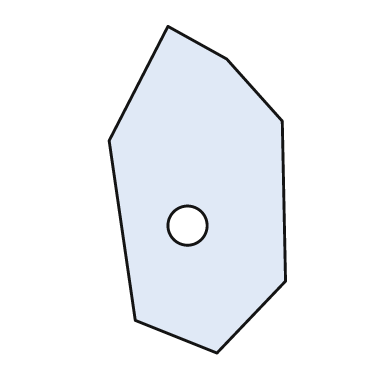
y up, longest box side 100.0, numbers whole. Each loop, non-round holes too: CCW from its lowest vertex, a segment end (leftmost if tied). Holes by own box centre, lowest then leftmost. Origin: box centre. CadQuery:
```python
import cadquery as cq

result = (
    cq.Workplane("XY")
    .moveTo(6.0, -50.0)
    .lineTo(27.0, -28.0)
    .lineTo(26.0, 21.0)
    .lineTo(9.0, 40.0)
    .lineTo(-9.0, 50.0)
    .lineTo(-27.0, 15.0)
    .lineTo(-19.0, -40.0)
    .close()
    .moveTo(-3.0, -11.0)
    .circle(6.0)
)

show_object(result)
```